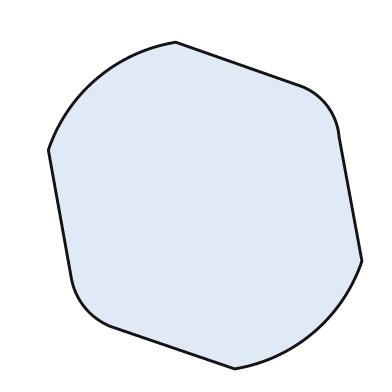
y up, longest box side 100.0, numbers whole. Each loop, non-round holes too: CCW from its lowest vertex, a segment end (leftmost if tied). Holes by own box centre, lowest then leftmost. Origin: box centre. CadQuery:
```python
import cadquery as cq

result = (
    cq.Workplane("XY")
    .moveTo(9.0, -50.0)
    .threePointArc((33.0, -39.0), (48.0, -17.0))
    .lineTo(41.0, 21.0)
    .threePointArc((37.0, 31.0), (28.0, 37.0))
    .lineTo(-9.0, 50.0)
    .threePointArc((-33.0, 39.0), (-48.0, 17.0))
    .lineTo(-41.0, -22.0)
    .threePointArc((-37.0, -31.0), (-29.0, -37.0))
    .close()
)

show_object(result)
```